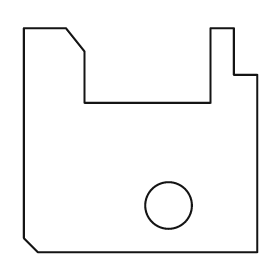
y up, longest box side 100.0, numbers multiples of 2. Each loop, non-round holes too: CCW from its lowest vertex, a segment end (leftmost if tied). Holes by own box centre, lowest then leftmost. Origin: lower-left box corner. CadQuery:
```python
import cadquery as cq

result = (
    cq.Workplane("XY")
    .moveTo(6.0, 0.0)
    .lineTo(100.0, 0.0)
    .lineTo(100.0, 76.0)
    .lineTo(90.0, 76.0)
    .lineTo(90.0, 96.0)
    .lineTo(80.0, 96.0)
    .lineTo(80.0, 64.0)
    .lineTo(26.0, 64.0)
    .lineTo(26.0, 86.0)
    .lineTo(18.0, 96.0)
    .lineTo(0.0, 96.0)
    .lineTo(0.0, 6.0)
    .close()
    .moveTo(62.0, 20.0)
    .circle(10.0)
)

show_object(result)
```